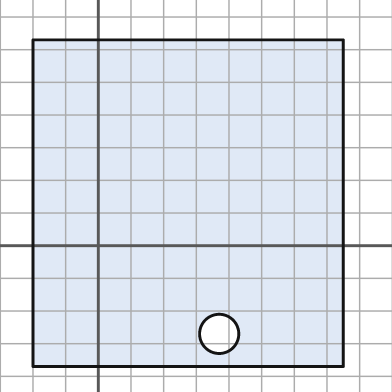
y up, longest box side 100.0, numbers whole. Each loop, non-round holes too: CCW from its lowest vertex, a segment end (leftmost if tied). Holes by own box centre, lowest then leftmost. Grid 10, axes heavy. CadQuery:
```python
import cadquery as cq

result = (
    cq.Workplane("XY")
    .moveTo(-20.0, -37.0)
    .lineTo(75.0, -37.0)
    .lineTo(75.0, 63.0)
    .lineTo(-20.0, 63.0)
    .close()
    .moveTo(37.0, -27.0)
    .circle(6.0)
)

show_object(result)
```